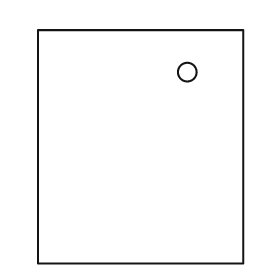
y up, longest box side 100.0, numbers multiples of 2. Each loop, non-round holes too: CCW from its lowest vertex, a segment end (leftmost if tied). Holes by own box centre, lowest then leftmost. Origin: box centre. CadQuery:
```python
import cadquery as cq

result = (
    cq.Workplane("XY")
    .moveTo(-44.0, -50.0)
    .lineTo(44.0, -50.0)
    .lineTo(44.0, 50.0)
    .lineTo(-44.0, 50.0)
    .close()
    .moveTo(20.0, 32.0)
    .circle(4.0)
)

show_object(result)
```